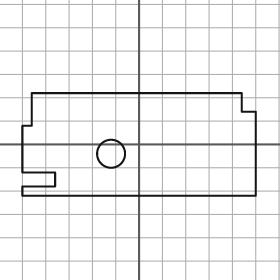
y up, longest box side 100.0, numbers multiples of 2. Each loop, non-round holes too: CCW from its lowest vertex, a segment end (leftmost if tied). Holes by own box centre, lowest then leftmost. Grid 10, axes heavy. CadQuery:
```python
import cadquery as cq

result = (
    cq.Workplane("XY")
    .moveTo(-50.0, -22.0)
    .lineTo(50.0, -22.0)
    .lineTo(50.0, 14.0)
    .lineTo(44.0, 14.0)
    .lineTo(44.0, 22.0)
    .lineTo(-46.0, 22.0)
    .lineTo(-46.0, 8.0)
    .lineTo(-50.0, 8.0)
    .lineTo(-50.0, -12.0)
    .lineTo(-36.0, -12.0)
    .lineTo(-36.0, -18.0)
    .lineTo(-50.0, -18.0)
    .close()
    .moveTo(-12.0, -4.0)
    .circle(6.0)
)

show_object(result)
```